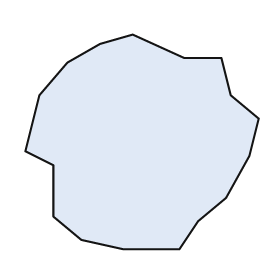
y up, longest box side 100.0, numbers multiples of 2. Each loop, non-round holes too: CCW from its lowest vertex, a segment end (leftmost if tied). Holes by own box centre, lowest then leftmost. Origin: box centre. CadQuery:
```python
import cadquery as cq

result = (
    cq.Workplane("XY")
    .moveTo(-8.0, -46.0)
    .lineTo(16.0, -46.0)
    .lineTo(24.0, -34.0)
    .lineTo(36.0, -24.0)
    .lineTo(46.0, -6.0)
    .lineTo(50.0, 10.0)
    .lineTo(38.0, 20.0)
    .lineTo(34.0, 36.0)
    .lineTo(18.0, 36.0)
    .lineTo(-4.0, 46.0)
    .lineTo(-18.0, 42.0)
    .lineTo(-32.0, 34.0)
    .lineTo(-44.0, 20.0)
    .lineTo(-50.0, -4.0)
    .lineTo(-38.0, -10.0)
    .lineTo(-38.0, -32.0)
    .lineTo(-26.0, -42.0)
    .close()
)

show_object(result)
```